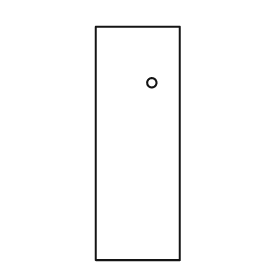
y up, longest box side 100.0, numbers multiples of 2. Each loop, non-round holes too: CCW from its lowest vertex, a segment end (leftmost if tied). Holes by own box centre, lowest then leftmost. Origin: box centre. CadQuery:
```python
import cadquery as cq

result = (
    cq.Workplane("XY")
    .moveTo(-18.0, -50.0)
    .lineTo(18.0, -50.0)
    .lineTo(18.0, 50.0)
    .lineTo(-18.0, 50.0)
    .close()
    .moveTo(6.0, 26.0)
    .circle(2.0)
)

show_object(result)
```